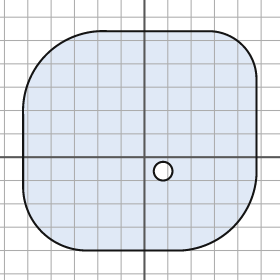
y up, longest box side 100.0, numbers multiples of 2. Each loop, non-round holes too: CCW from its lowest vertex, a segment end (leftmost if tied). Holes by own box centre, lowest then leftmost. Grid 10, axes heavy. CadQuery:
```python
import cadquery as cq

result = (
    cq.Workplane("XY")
    .moveTo(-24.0, -40.0)
    .lineTo(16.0, -40.0)
    .threePointArc((38.0, -30.0), (48.0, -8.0))
    .lineTo(48.0, 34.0)
    .threePointArc((42.0, 48.0), (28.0, 54.0))
    .lineTo(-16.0, 54.0)
    .threePointArc((-42.0, 44.0), (-52.0, 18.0))
    .lineTo(-52.0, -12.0)
    .threePointArc((-44.0, -32.0), (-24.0, -40.0))
    .close()
    .moveTo(8.0, -6.0)
    .circle(4.0)
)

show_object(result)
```